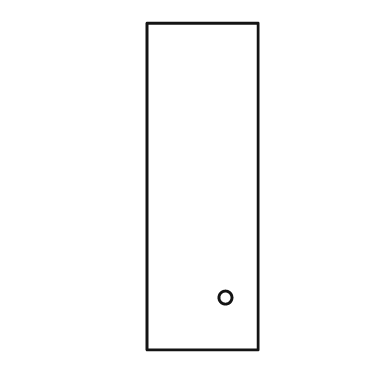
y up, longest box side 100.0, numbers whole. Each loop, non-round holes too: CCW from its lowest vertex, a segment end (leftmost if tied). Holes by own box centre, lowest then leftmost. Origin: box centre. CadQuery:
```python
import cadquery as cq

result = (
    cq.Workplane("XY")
    .moveTo(-17.0, -50.0)
    .lineTo(17.0, -50.0)
    .lineTo(17.0, 50.0)
    .lineTo(-17.0, 50.0)
    .close()
    .moveTo(7.0, -34.0)
    .circle(2.0)
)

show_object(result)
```